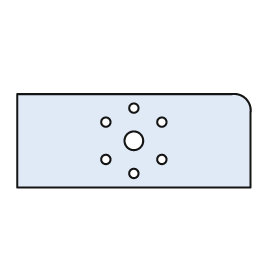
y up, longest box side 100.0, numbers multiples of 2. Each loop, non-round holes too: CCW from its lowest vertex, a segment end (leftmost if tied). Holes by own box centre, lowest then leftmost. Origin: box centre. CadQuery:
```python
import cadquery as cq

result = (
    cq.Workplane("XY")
    .moveTo(-50.0, -20.0)
    .lineTo(50.0, -20.0)
    .lineTo(50.0, 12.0)
    .threePointArc((48.0, 18.0), (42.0, 20.0))
    .lineTo(-50.0, 20.0)
    .close()
    .moveTo(0.0, -14.0)
    .circle(2.0)
    .moveTo(-12.0, -8.0)
    .circle(2.0)
    .moveTo(12.0, -8.0)
    .circle(2.0)
    .moveTo(0.0, 0.0)
    .circle(4.0)
    .moveTo(-12.0, 8.0)
    .circle(2.0)
    .moveTo(12.0, 8.0)
    .circle(2.0)
    .moveTo(0.0, 14.0)
    .circle(2.0)
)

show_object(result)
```